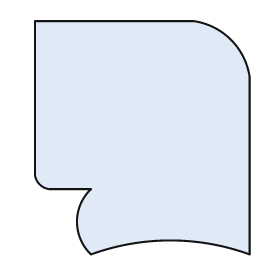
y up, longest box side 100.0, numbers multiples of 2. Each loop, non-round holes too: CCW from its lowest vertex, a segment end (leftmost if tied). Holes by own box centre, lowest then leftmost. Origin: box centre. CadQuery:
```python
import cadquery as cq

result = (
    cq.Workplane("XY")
    .moveTo(-22.0, -50.0)
    .threePointArc((12.0, -44.0), (46.0, -50.0))
    .lineTo(46.0, 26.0)
    .threePointArc((38.0, 42.0), (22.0, 50.0))
    .lineTo(-46.0, 50.0)
    .lineTo(-46.0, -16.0)
    .threePointArc((-44.0, -20.0), (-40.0, -22.0))
    .lineTo(-22.0, -22.0)
    .threePointArc((-28.0, -36.0), (-22.0, -50.0))
    .close()
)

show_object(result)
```